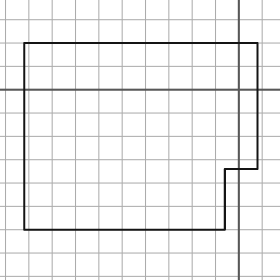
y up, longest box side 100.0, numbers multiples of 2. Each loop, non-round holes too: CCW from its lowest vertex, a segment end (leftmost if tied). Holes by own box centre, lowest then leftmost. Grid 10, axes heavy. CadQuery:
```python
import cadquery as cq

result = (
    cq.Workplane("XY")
    .moveTo(-92.0, -60.0)
    .lineTo(-6.0, -60.0)
    .lineTo(-6.0, -34.0)
    .lineTo(8.0, -34.0)
    .lineTo(8.0, 20.0)
    .lineTo(-92.0, 20.0)
    .close()
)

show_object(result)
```